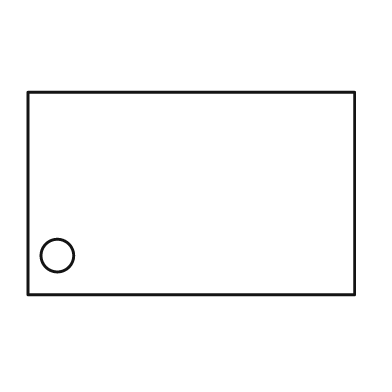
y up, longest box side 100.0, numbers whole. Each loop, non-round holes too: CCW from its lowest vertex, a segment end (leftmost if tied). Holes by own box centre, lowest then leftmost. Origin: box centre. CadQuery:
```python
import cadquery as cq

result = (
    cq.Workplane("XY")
    .moveTo(-50.0, -31.0)
    .lineTo(50.0, -31.0)
    .lineTo(50.0, 31.0)
    .lineTo(-50.0, 31.0)
    .close()
    .moveTo(-41.0, -19.0)
    .circle(5.0)
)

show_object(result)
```